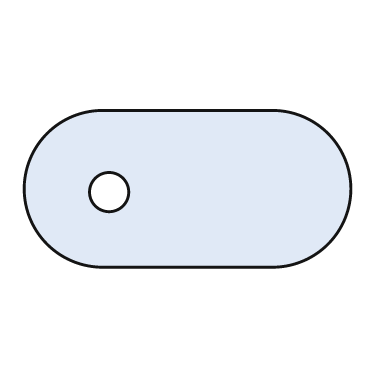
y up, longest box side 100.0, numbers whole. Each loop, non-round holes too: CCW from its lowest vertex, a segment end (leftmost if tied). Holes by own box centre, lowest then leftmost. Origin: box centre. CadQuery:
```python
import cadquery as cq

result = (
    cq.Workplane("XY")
    .moveTo(-26.0, -24.0)
    .lineTo(26.0, -24.0)
    .threePointArc((50.0, 0.0), (26.0, 24.0))
    .lineTo(-26.0, 24.0)
    .threePointArc((-50.0, 0.0), (-26.0, -24.0))
    .close()
    .moveTo(-24.0, -1.0)
    .circle(6.0)
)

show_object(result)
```